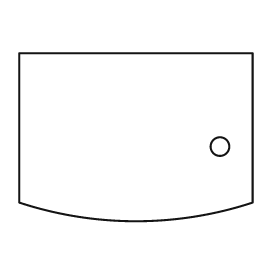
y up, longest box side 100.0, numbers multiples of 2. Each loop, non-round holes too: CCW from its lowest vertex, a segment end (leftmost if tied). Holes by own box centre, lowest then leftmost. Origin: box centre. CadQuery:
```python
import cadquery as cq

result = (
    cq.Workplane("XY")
    .moveTo(-50.0, -28.0)
    .threePointArc((0.0, -36.0), (50.0, -28.0))
    .lineTo(50.0, 36.0)
    .lineTo(-50.0, 36.0)
    .close()
    .moveTo(36.0, -4.0)
    .circle(4.0)
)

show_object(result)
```